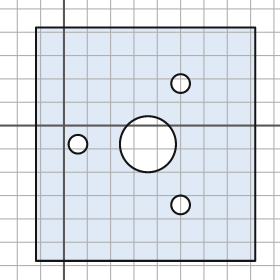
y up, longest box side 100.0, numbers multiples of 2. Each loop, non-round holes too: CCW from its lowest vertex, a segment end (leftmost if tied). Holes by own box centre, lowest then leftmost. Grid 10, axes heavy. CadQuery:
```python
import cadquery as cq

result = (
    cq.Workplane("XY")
    .moveTo(-12.0, -58.0)
    .lineTo(82.0, -58.0)
    .lineTo(82.0, 42.0)
    .lineTo(-12.0, 42.0)
    .close()
    .moveTo(50.0, -34.0)
    .circle(4.0)
    .moveTo(6.0, -8.0)
    .circle(4.0)
    .moveTo(36.0, -8.0)
    .circle(12.0)
    .moveTo(50.0, 18.0)
    .circle(4.0)
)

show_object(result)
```